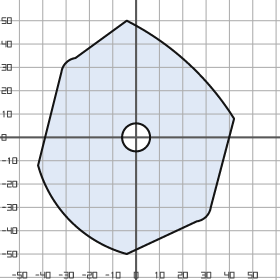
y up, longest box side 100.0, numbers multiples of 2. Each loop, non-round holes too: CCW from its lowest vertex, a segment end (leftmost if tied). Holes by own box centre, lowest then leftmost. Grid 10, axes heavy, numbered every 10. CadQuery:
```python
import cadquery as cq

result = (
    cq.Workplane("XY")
    .moveTo(-4.0, -50.0)
    .lineTo(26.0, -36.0)
    .threePointArc((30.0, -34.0), (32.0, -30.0))
    .lineTo(42.0, 8.0)
    .threePointArc((22.0, 32.0), (-4.0, 50.0))
    .lineTo(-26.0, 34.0)
    .threePointArc((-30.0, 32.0), (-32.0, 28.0))
    .lineTo(-42.0, -12.0)
    .threePointArc((-28.0, -36.0), (-4.0, -50.0))
    .close()
    .moveTo(0.0, 0.0)
    .circle(6.0)
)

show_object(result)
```